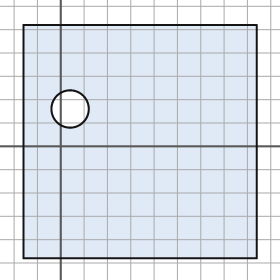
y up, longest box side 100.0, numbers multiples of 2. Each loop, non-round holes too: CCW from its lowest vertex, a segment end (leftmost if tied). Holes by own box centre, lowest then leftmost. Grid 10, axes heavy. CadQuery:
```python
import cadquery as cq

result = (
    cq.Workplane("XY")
    .moveTo(-16.0, -48.0)
    .lineTo(84.0, -48.0)
    .lineTo(84.0, 52.0)
    .lineTo(-16.0, 52.0)
    .close()
    .moveTo(4.0, 16.0)
    .circle(8.0)
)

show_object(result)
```